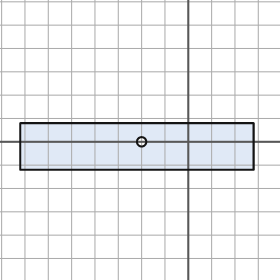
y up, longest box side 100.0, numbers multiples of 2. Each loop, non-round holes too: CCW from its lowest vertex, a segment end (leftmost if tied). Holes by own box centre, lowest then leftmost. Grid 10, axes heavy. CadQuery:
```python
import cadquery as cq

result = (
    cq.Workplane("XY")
    .moveTo(-72.0, -12.0)
    .lineTo(28.0, -12.0)
    .lineTo(28.0, 8.0)
    .lineTo(-72.0, 8.0)
    .close()
    .moveTo(-20.0, 0.0)
    .circle(2.0)
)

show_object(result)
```